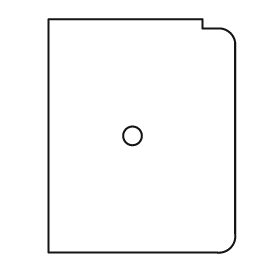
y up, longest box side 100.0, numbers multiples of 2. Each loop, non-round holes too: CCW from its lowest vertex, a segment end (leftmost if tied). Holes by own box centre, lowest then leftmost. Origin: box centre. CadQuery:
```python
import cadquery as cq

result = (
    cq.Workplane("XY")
    .moveTo(-40.0, -50.0)
    .lineTo(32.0, -50.0)
    .threePointArc((38.0, -48.0), (40.0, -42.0))
    .lineTo(40.0, 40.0)
    .threePointArc((38.0, 44.0), (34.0, 46.0))
    .lineTo(26.0, 46.0)
    .lineTo(26.0, 50.0)
    .lineTo(-40.0, 50.0)
    .close()
    .moveTo(-4.0, 0.0)
    .circle(4.0)
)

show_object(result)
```